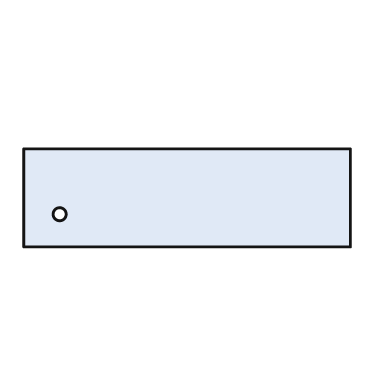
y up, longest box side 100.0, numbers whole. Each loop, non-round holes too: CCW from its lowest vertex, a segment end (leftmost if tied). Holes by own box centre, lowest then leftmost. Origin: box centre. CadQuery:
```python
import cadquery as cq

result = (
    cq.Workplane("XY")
    .moveTo(-50.0, -15.0)
    .lineTo(50.0, -15.0)
    .lineTo(50.0, 15.0)
    .lineTo(-50.0, 15.0)
    .close()
    .moveTo(-39.0, -5.0)
    .circle(2.0)
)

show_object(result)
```